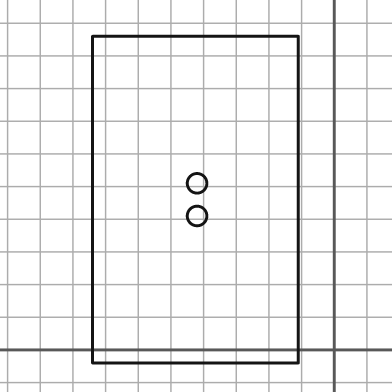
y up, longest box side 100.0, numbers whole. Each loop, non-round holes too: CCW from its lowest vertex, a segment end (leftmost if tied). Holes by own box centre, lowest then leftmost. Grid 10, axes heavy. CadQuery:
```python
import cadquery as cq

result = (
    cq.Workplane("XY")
    .moveTo(-74.0, -4.0)
    .lineTo(-11.0, -4.0)
    .lineTo(-11.0, 96.0)
    .lineTo(-74.0, 96.0)
    .close()
    .moveTo(-42.0, 41.0)
    .circle(3.0)
    .moveTo(-42.0, 51.0)
    .circle(3.0)
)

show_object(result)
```